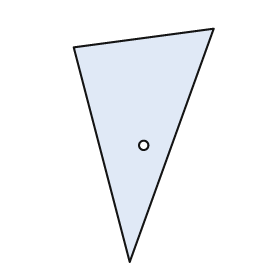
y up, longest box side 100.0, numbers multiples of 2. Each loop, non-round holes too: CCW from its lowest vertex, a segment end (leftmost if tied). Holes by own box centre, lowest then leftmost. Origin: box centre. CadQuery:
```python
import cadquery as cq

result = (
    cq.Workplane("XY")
    .moveTo(-6.0, -50.0)
    .lineTo(30.0, 50.0)
    .lineTo(-30.0, 42.0)
    .close()
    .moveTo(0.0, 0.0)
    .circle(2.0)
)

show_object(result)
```